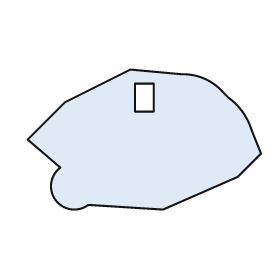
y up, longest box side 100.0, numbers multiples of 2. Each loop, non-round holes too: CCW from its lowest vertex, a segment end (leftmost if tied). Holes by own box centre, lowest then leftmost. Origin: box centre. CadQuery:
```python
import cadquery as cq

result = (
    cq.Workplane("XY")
    .moveTo(8.0, -30.0)
    .lineTo(40.0, -16.0)
    .lineTo(50.0, -6.0)
    .lineTo(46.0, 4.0)
    .threePointArc((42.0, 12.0), (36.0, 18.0))
    .lineTo(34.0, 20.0)
    .threePointArc((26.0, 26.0), (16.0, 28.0))
    .lineTo(-6.0, 30.0)
    .lineTo(-34.0, 16.0)
    .lineTo(-50.0, 0.0)
    .lineTo(-36.0, -12.0)
    .threePointArc((-38.0, -26.0), (-24.0, -28.0))
    .close()
    .moveTo(-4.0, 12.0)
    .lineTo(4.0, 12.0)
    .lineTo(4.0, 24.0)
    .lineTo(-4.0, 24.0)
    .close()
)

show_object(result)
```